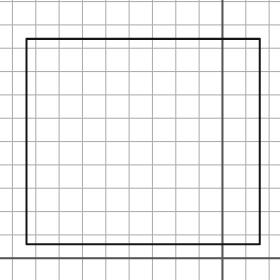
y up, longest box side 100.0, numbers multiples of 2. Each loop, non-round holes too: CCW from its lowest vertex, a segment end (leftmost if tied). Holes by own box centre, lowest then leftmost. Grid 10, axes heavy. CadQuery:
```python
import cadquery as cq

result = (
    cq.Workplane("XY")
    .moveTo(-84.0, 6.0)
    .lineTo(16.0, 6.0)
    .lineTo(16.0, 94.0)
    .lineTo(-84.0, 94.0)
    .close()
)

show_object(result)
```